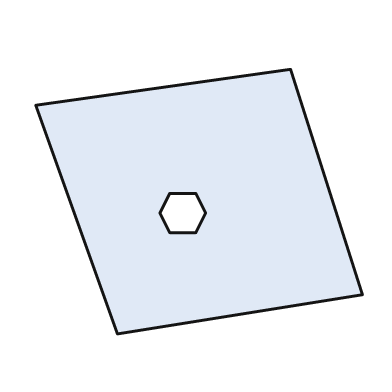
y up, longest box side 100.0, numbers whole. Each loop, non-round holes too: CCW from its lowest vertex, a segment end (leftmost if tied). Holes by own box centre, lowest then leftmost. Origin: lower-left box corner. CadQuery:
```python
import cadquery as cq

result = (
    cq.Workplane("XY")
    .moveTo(25.0, 0.0)
    .lineTo(100.0, 12.0)
    .lineTo(78.0, 81.0)
    .lineTo(0.0, 70.0)
    .close()
    .moveTo(41.0, 31.0)
    .lineTo(49.0, 31.0)
    .lineTo(52.0, 37.0)
    .lineTo(49.0, 43.0)
    .lineTo(41.0, 43.0)
    .lineTo(38.0, 37.0)
    .close()
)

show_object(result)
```